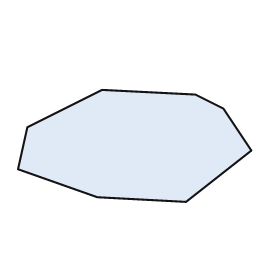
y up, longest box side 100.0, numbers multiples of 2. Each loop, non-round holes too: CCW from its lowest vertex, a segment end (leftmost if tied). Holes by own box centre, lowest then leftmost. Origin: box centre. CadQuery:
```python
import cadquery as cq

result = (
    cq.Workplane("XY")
    .moveTo(22.0, -24.0)
    .lineTo(50.0, -2.0)
    .lineTo(38.0, 16.0)
    .lineTo(26.0, 22.0)
    .lineTo(-14.0, 24.0)
    .lineTo(-46.0, 8.0)
    .lineTo(-50.0, -10.0)
    .lineTo(-16.0, -22.0)
    .close()
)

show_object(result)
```